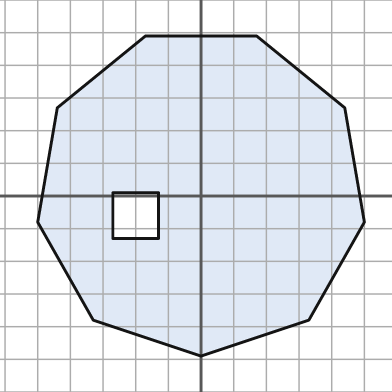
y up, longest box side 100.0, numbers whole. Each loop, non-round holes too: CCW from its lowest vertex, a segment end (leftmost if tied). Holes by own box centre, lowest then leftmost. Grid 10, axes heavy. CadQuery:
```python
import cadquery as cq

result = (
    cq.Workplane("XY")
    .moveTo(0.0, -49.0)
    .lineTo(33.0, -38.0)
    .lineTo(50.0, -8.0)
    .lineTo(44.0, 27.0)
    .lineTo(17.0, 49.0)
    .lineTo(-17.0, 49.0)
    .lineTo(-44.0, 27.0)
    .lineTo(-50.0, -8.0)
    .lineTo(-33.0, -38.0)
    .close()
    .moveTo(-27.0, -13.0)
    .lineTo(-13.0, -13.0)
    .lineTo(-13.0, 1.0)
    .lineTo(-27.0, 1.0)
    .close()
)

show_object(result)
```